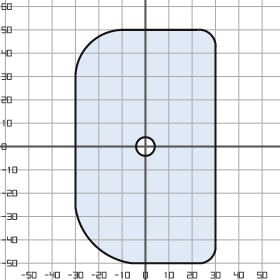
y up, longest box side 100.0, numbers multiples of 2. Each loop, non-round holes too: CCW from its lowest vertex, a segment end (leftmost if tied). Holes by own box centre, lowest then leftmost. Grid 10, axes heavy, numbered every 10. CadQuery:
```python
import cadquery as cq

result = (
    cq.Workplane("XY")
    .moveTo(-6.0, -50.0)
    .lineTo(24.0, -50.0)
    .threePointArc((28.0, -48.0), (30.0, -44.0))
    .lineTo(30.0, 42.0)
    .threePointArc((28.0, 48.0), (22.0, 50.0))
    .lineTo(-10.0, 50.0)
    .threePointArc((-24.0, 44.0), (-30.0, 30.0))
    .lineTo(-30.0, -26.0)
    .threePointArc((-22.0, -42.0), (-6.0, -50.0))
    .close()
    .moveTo(0.0, 0.0)
    .circle(4.0)
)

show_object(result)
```